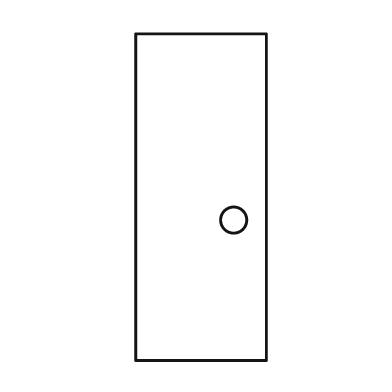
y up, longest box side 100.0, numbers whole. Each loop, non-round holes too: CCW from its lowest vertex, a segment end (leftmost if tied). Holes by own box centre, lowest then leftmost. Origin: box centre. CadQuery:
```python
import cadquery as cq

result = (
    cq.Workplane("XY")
    .moveTo(-20.0, -50.0)
    .lineTo(20.0, -50.0)
    .lineTo(20.0, 50.0)
    .lineTo(-20.0, 50.0)
    .close()
    .moveTo(10.0, -7.0)
    .circle(4.0)
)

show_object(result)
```